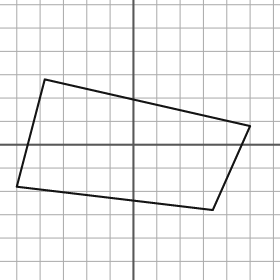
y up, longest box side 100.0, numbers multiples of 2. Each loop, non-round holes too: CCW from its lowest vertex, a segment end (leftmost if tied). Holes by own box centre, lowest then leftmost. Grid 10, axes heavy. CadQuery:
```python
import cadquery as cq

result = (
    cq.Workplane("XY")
    .moveTo(34.0, -28.0)
    .lineTo(50.0, 8.0)
    .lineTo(-38.0, 28.0)
    .lineTo(-50.0, -18.0)
    .close()
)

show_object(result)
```